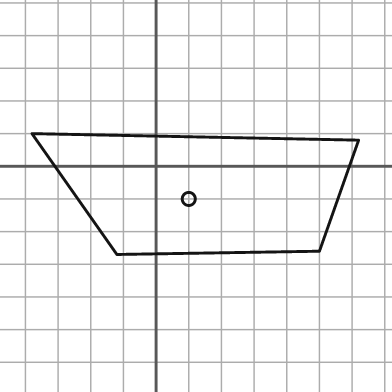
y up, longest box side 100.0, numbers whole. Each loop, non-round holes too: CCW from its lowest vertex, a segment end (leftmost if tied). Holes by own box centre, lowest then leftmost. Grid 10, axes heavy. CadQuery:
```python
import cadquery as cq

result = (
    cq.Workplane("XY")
    .moveTo(-12.0, -27.0)
    .lineTo(50.0, -26.0)
    .lineTo(62.0, 8.0)
    .lineTo(-38.0, 10.0)
    .close()
    .moveTo(10.0, -10.0)
    .circle(2.0)
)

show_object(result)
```